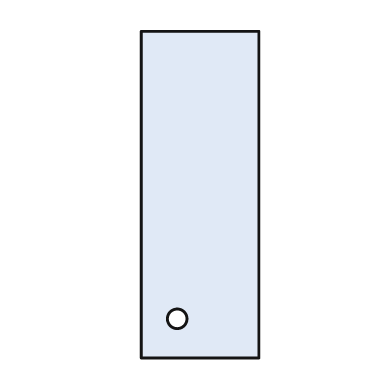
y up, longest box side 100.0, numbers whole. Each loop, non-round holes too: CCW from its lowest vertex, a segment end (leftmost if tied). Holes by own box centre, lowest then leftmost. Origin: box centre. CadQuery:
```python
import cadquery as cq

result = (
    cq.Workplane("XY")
    .moveTo(-18.0, -50.0)
    .lineTo(18.0, -50.0)
    .lineTo(18.0, 50.0)
    .lineTo(-18.0, 50.0)
    .close()
    .moveTo(-7.0, -38.0)
    .circle(3.0)
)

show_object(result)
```